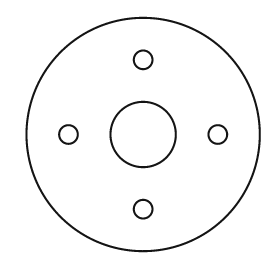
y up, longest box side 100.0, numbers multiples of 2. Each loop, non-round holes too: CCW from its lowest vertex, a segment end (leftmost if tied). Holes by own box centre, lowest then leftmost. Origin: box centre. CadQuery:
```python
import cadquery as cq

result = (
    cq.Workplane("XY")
    .moveTo(0.0, 0.0)
    .circle(50.0)
    .moveTo(0.0, -32.0)
    .circle(4.0)
    .moveTo(-32.0, 0.0)
    .circle(4.0)
    .moveTo(0.0, 0.0)
    .circle(14.0)
    .moveTo(32.0, 0.0)
    .circle(4.0)
    .moveTo(0.0, 32.0)
    .circle(4.0)
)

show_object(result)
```